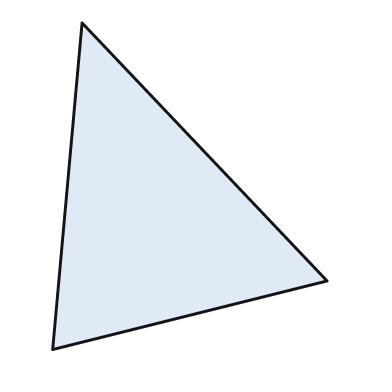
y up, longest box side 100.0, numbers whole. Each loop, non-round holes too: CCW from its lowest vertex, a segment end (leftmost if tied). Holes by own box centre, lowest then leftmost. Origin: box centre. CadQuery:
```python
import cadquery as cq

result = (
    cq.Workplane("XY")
    .moveTo(-42.0, -50.0)
    .lineTo(42.0, -29.0)
    .lineTo(-33.0, 50.0)
    .close()
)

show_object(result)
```